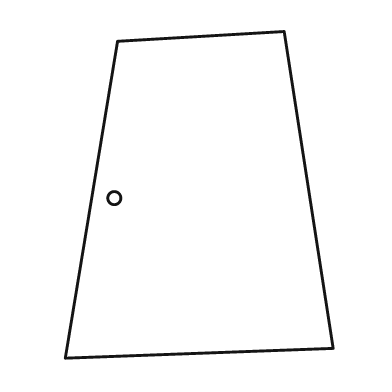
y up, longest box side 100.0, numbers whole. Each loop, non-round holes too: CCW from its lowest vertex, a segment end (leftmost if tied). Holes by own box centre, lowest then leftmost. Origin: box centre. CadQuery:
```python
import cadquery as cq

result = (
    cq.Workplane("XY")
    .moveTo(-41.0, -50.0)
    .lineTo(41.0, -47.0)
    .lineTo(26.0, 50.0)
    .lineTo(-25.0, 47.0)
    .close()
    .moveTo(-26.0, -1.0)
    .circle(2.0)
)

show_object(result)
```